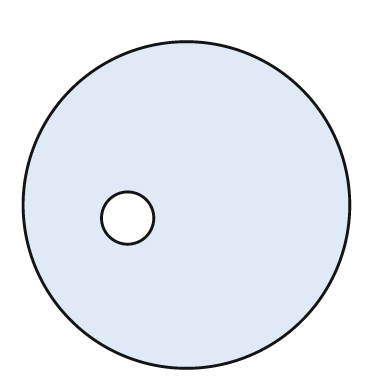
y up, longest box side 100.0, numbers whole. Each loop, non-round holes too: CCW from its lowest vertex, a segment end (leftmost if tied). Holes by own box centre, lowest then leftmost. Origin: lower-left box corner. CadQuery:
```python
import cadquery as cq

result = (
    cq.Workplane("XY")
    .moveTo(50.0, 50.0)
    .circle(50.0)
    .moveTo(32.0, 46.0)
    .circle(8.0)
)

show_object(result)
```